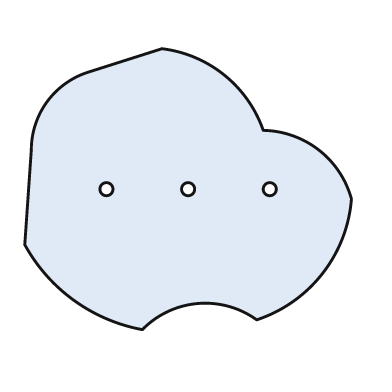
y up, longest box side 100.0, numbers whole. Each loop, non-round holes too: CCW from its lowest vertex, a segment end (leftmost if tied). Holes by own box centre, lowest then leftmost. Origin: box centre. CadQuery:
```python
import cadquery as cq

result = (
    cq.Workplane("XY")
    .moveTo(-14.0, -43.0)
    .threePointArc((3.0, -35.0), (21.0, -40.0))
    .threePointArc((41.0, -26.0), (50.0, -3.0))
    .threePointArc((40.0, 12.0), (23.0, 18.0))
    .threePointArc((11.0, 35.0), (-8.0, 43.0))
    .lineTo(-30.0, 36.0)
    .threePointArc((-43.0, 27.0), (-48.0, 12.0))
    .lineTo(-50.0, -17.0)
    .threePointArc((-35.0, -34.0), (-14.0, -43.0))
    .close()
    .moveTo(-25.0, 0.0)
    .circle(2.0)
    .moveTo(0.0, 0.0)
    .circle(2.0)
    .moveTo(25.0, 0.0)
    .circle(2.0)
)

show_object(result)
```